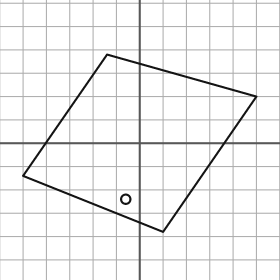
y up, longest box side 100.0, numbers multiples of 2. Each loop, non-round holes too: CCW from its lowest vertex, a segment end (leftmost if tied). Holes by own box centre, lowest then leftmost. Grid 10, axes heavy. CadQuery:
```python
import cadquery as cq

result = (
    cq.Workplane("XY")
    .moveTo(10.0, -38.0)
    .lineTo(50.0, 20.0)
    .lineTo(-14.0, 38.0)
    .lineTo(-50.0, -14.0)
    .close()
    .moveTo(-6.0, -24.0)
    .circle(2.0)
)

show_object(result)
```